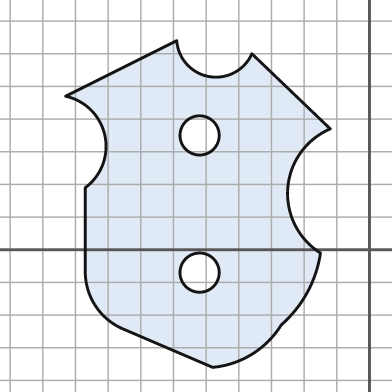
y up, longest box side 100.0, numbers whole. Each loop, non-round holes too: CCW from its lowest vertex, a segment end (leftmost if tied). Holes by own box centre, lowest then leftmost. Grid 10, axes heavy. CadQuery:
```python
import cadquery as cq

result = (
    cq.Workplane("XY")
    .moveTo(-48.0, -36.0)
    .threePointArc((-36.0, -32.0), (-27.0, -23.0))
    .threePointArc((-19.0, -13.0), (-15.0, -1.0))
    .threePointArc((-25.0, 19.0), (-12.0, 37.0))
    .lineTo(-36.0, 60.0)
    .threePointArc((-49.0, 53.0), (-59.0, 64.0))
    .lineTo(-93.0, 47.0)
    .threePointArc((-81.0, 35.0), (-87.0, 19.0))
    .lineTo(-87.0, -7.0)
    .threePointArc((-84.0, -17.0), (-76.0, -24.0))
    .close()
    .moveTo(-52.0, -7.0)
    .circle(6.0)
    .moveTo(-52.0, 35.0)
    .circle(6.0)
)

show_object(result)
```